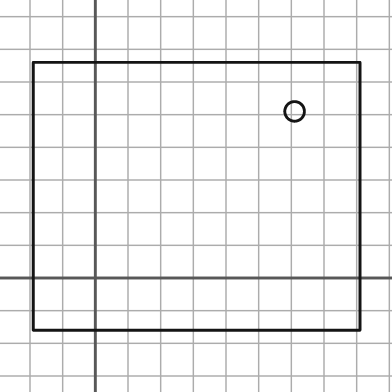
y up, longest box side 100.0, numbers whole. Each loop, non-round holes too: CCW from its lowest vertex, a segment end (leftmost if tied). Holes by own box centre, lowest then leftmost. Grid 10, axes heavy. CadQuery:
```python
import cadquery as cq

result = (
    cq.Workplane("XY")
    .moveTo(-19.0, -16.0)
    .lineTo(81.0, -16.0)
    .lineTo(81.0, 66.0)
    .lineTo(-19.0, 66.0)
    .close()
    .moveTo(61.0, 51.0)
    .circle(3.0)
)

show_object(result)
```